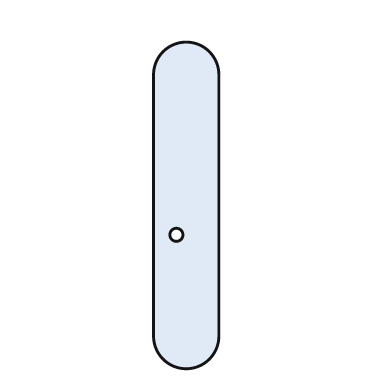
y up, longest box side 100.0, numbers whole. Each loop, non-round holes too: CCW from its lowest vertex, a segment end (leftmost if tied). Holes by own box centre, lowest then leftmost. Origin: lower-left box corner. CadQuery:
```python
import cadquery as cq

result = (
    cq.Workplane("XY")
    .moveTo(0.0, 10.0)
    .threePointArc((10.0, 0.0), (20.0, 10.0))
    .lineTo(20.0, 90.0)
    .threePointArc((10.0, 100.0), (0.0, 90.0))
    .close()
    .moveTo(7.0, 41.0)
    .circle(2.0)
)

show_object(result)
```